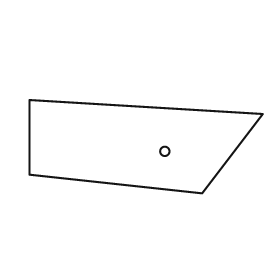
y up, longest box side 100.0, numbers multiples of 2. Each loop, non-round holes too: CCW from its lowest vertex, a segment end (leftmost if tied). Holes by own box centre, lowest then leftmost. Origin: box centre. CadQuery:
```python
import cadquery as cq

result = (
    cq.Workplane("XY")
    .moveTo(24.0, -20.0)
    .lineTo(50.0, 14.0)
    .lineTo(-50.0, 20.0)
    .lineTo(-50.0, -12.0)
    .close()
    .moveTo(8.0, -2.0)
    .circle(2.0)
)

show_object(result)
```